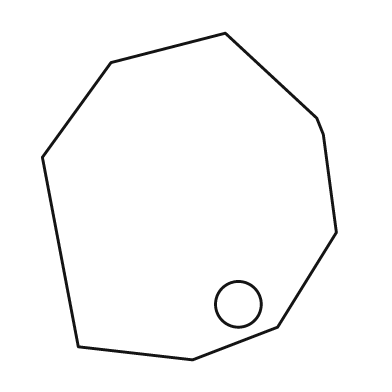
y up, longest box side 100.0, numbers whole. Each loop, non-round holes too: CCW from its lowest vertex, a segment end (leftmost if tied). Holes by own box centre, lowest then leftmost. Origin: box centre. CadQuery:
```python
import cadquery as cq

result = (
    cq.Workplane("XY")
    .moveTo(1.0, -50.0)
    .lineTo(27.0, -40.0)
    .lineTo(45.0, -11.0)
    .lineTo(41.0, 19.0)
    .lineTo(39.0, 24.0)
    .lineTo(11.0, 50.0)
    .lineTo(-24.0, 41.0)
    .lineTo(-45.0, 12.0)
    .lineTo(-34.0, -46.0)
    .close()
    .moveTo(15.0, -33.0)
    .circle(7.0)
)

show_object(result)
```